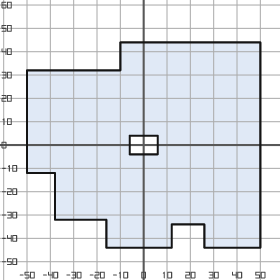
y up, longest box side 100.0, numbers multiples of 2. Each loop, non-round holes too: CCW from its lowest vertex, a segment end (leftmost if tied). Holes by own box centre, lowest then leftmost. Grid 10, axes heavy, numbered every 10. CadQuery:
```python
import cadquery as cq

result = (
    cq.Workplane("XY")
    .moveTo(-16.0, -44.0)
    .lineTo(12.0, -44.0)
    .lineTo(12.0, -34.0)
    .lineTo(26.0, -34.0)
    .lineTo(26.0, -44.0)
    .lineTo(50.0, -44.0)
    .lineTo(50.0, 44.0)
    .lineTo(-10.0, 44.0)
    .lineTo(-10.0, 32.0)
    .lineTo(-50.0, 32.0)
    .lineTo(-50.0, -12.0)
    .lineTo(-38.0, -12.0)
    .lineTo(-38.0, -32.0)
    .lineTo(-16.0, -32.0)
    .close()
    .moveTo(-6.0, -4.0)
    .lineTo(6.0, -4.0)
    .lineTo(6.0, 4.0)
    .lineTo(-6.0, 4.0)
    .close()
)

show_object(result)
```